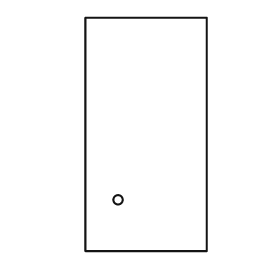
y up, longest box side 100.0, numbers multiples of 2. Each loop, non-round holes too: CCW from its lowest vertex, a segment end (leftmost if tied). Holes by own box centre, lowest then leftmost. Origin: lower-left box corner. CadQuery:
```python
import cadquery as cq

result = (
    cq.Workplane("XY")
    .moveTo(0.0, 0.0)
    .lineTo(52.0, 0.0)
    .lineTo(52.0, 100.0)
    .lineTo(0.0, 100.0)
    .close()
    .moveTo(14.0, 22.0)
    .circle(2.0)
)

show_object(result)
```